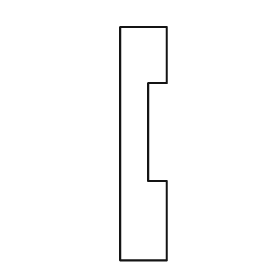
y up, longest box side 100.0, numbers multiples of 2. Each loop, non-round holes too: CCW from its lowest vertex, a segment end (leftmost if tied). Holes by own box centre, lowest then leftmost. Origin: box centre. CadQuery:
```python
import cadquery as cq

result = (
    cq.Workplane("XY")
    .moveTo(-10.0, -50.0)
    .lineTo(10.0, -50.0)
    .lineTo(10.0, -16.0)
    .lineTo(2.0, -16.0)
    .lineTo(2.0, 26.0)
    .lineTo(10.0, 26.0)
    .lineTo(10.0, 50.0)
    .lineTo(-10.0, 50.0)
    .close()
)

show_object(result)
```